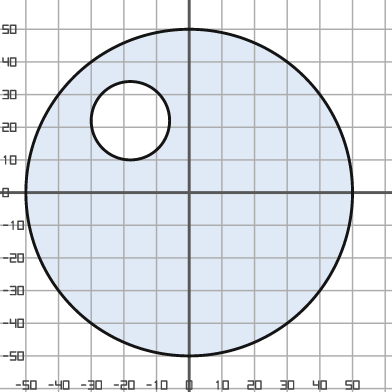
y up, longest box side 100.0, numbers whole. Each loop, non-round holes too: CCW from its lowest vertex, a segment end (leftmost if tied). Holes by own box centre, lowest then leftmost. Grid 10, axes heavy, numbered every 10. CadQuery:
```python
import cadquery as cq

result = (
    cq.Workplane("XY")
    .moveTo(0.0, 0.0)
    .circle(50.0)
    .moveTo(-18.0, 22.0)
    .circle(12.0)
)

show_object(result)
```